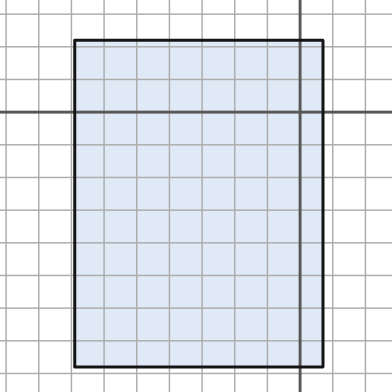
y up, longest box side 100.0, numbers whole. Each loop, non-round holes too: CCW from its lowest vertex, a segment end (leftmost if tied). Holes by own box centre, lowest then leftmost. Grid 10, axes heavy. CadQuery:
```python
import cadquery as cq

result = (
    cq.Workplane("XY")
    .moveTo(-69.0, -78.0)
    .lineTo(7.0, -78.0)
    .lineTo(7.0, 22.0)
    .lineTo(-69.0, 22.0)
    .close()
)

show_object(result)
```